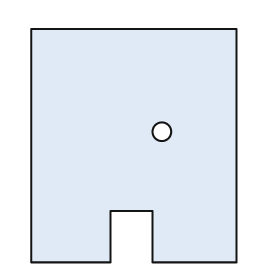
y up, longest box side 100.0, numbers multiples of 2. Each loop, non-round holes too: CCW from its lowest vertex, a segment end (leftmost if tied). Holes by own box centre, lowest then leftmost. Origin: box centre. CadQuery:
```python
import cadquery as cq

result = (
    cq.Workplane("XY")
    .moveTo(-44.0, -50.0)
    .lineTo(-10.0, -50.0)
    .lineTo(-10.0, -28.0)
    .lineTo(8.0, -28.0)
    .lineTo(8.0, -50.0)
    .lineTo(44.0, -50.0)
    .lineTo(44.0, 50.0)
    .lineTo(-44.0, 50.0)
    .close()
    .moveTo(12.0, 6.0)
    .circle(4.0)
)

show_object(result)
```